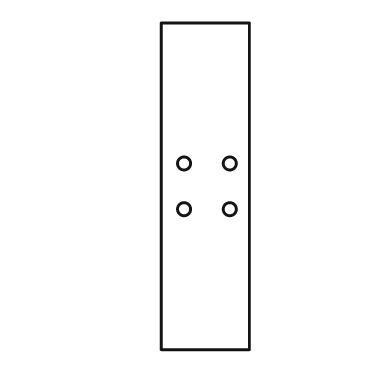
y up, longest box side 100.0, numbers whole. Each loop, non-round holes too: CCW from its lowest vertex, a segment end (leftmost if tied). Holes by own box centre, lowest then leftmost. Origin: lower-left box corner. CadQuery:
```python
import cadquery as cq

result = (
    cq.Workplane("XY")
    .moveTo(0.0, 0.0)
    .lineTo(27.0, 0.0)
    .lineTo(27.0, 100.0)
    .lineTo(0.0, 100.0)
    .close()
    .moveTo(7.0, 43.0)
    .circle(2.0)
    .moveTo(21.0, 43.0)
    .circle(2.0)
    .moveTo(7.0, 57.0)
    .circle(2.0)
    .moveTo(21.0, 57.0)
    .circle(2.0)
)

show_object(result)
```